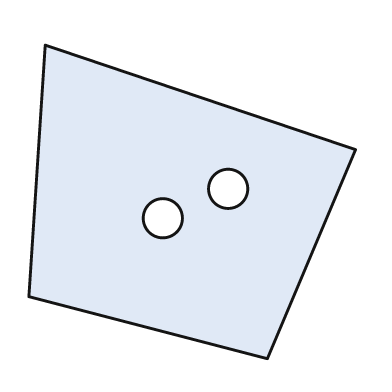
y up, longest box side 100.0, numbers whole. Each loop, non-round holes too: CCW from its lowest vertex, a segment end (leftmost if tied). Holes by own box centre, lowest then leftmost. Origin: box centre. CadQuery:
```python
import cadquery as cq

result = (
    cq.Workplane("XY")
    .moveTo(23.0, -48.0)
    .lineTo(50.0, 16.0)
    .lineTo(-45.0, 48.0)
    .lineTo(-50.0, -29.0)
    .close()
    .moveTo(-9.0, -5.0)
    .circle(6.0)
    .moveTo(11.0, 4.0)
    .circle(6.0)
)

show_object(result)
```